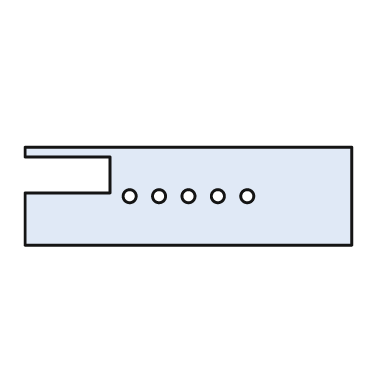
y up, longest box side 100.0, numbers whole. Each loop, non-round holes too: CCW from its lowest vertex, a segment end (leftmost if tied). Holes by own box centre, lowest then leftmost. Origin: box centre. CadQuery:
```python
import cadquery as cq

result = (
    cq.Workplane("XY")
    .moveTo(-50.0, -15.0)
    .lineTo(50.0, -15.0)
    .lineTo(50.0, 15.0)
    .lineTo(-50.0, 15.0)
    .lineTo(-50.0, 12.0)
    .lineTo(-24.0, 12.0)
    .lineTo(-24.0, 1.0)
    .lineTo(-50.0, 1.0)
    .close()
    .moveTo(-18.0, 0.0)
    .circle(2.0)
    .moveTo(-9.0, 0.0)
    .circle(2.0)
    .moveTo(0.0, 0.0)
    .circle(2.0)
    .moveTo(9.0, 0.0)
    .circle(2.0)
    .moveTo(18.0, 0.0)
    .circle(2.0)
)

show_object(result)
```